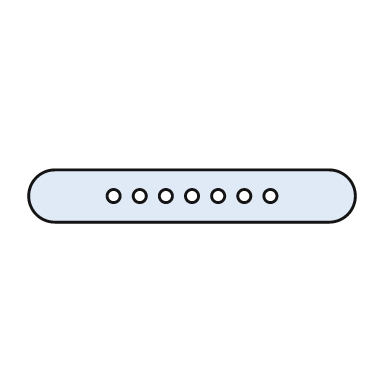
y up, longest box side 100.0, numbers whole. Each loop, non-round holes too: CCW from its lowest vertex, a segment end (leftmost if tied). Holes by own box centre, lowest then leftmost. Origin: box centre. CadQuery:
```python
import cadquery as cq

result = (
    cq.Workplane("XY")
    .moveTo(-42.0, -8.0)
    .lineTo(42.0, -8.0)
    .threePointArc((50.0, 0.0), (42.0, 8.0))
    .lineTo(-42.0, 8.0)
    .threePointArc((-50.0, 0.0), (-42.0, -8.0))
    .close()
    .moveTo(-24.0, 0.0)
    .circle(2.0)
    .moveTo(-16.0, 0.0)
    .circle(2.0)
    .moveTo(-8.0, 0.0)
    .circle(2.0)
    .moveTo(0.0, 0.0)
    .circle(2.0)
    .moveTo(8.0, 0.0)
    .circle(2.0)
    .moveTo(16.0, 0.0)
    .circle(2.0)
    .moveTo(24.0, 0.0)
    .circle(2.0)
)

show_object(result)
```